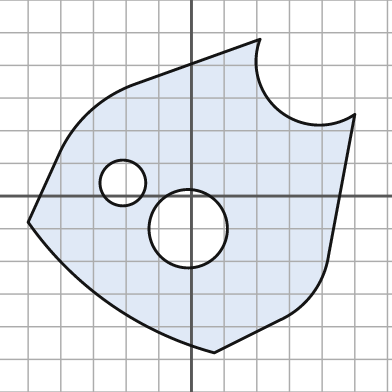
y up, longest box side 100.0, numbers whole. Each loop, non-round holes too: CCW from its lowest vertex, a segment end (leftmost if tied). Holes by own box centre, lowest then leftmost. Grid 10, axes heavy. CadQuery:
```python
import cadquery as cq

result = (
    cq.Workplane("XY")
    .moveTo(7.0, -48.0)
    .lineTo(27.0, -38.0)
    .threePointArc((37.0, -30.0), (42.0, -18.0))
    .lineTo(50.0, 25.0)
    .threePointArc((27.0, 26.0), (21.0, 48.0))
    .lineTo(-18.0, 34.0)
    .threePointArc((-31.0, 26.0), (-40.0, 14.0))
    .lineTo(-50.0, -8.0)
    .threePointArc((-25.0, -33.0), (7.0, -48.0))
    .close()
    .moveTo(-1.0, -10.0)
    .circle(12.0)
    .moveTo(-21.0, 4.0)
    .circle(7.0)
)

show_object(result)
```